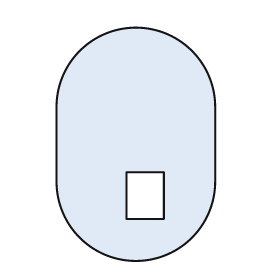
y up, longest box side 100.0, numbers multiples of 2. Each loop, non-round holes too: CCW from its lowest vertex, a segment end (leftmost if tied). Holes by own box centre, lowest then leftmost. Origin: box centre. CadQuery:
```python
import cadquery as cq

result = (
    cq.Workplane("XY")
    .moveTo(-34.0, -16.0)
    .threePointArc((0.0, -50.0), (34.0, -16.0))
    .lineTo(34.0, 16.0)
    .threePointArc((0.0, 50.0), (-34.0, 16.0))
    .close()
    .moveTo(-4.0, -32.0)
    .lineTo(12.0, -32.0)
    .lineTo(12.0, -12.0)
    .lineTo(-4.0, -12.0)
    .close()
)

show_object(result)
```